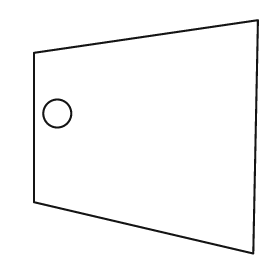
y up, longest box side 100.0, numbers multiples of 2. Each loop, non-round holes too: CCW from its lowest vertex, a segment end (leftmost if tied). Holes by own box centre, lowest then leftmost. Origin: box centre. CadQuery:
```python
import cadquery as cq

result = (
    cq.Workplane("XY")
    .moveTo(46.0, -50.0)
    .lineTo(48.0, 50.0)
    .lineTo(-48.0, 36.0)
    .lineTo(-48.0, -28.0)
    .close()
    .moveTo(-38.0, 10.0)
    .circle(6.0)
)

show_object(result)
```